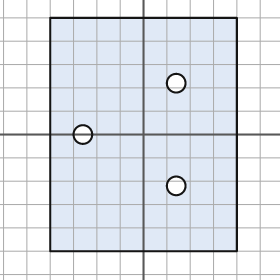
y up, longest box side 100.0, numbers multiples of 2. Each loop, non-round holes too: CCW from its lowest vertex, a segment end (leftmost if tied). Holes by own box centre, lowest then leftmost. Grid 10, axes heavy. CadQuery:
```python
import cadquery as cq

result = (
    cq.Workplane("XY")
    .moveTo(-40.0, -50.0)
    .lineTo(40.0, -50.0)
    .lineTo(40.0, 50.0)
    .lineTo(-40.0, 50.0)
    .close()
    .moveTo(14.0, -22.0)
    .circle(4.0)
    .moveTo(-26.0, 0.0)
    .circle(4.0)
    .moveTo(14.0, 22.0)
    .circle(4.0)
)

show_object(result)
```